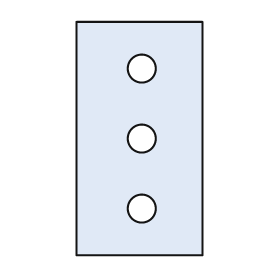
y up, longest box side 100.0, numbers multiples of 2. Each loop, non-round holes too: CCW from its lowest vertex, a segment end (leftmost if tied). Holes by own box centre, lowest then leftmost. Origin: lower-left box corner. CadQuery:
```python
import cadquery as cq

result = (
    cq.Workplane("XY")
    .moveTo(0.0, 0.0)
    .lineTo(54.0, 0.0)
    .lineTo(54.0, 100.0)
    .lineTo(0.0, 100.0)
    .close()
    .moveTo(28.0, 20.0)
    .circle(6.0)
    .moveTo(28.0, 50.0)
    .circle(6.0)
    .moveTo(28.0, 80.0)
    .circle(6.0)
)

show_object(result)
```